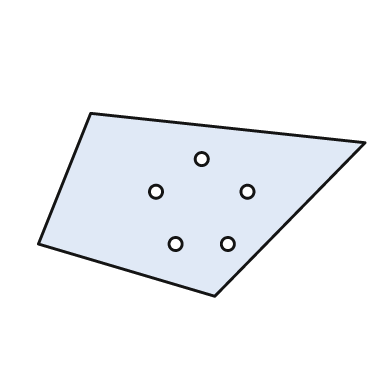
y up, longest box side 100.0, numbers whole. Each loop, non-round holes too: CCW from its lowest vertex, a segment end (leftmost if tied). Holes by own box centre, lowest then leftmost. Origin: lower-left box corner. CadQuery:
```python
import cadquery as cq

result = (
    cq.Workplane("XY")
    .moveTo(54.0, 0.0)
    .lineTo(100.0, 47.0)
    .lineTo(16.0, 56.0)
    .lineTo(0.0, 16.0)
    .close()
    .moveTo(42.0, 16.0)
    .circle(2.0)
    .moveTo(58.0, 16.0)
    .circle(2.0)
    .moveTo(36.0, 32.0)
    .circle(2.0)
    .moveTo(64.0, 32.0)
    .circle(2.0)
    .moveTo(50.0, 42.0)
    .circle(2.0)
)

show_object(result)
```